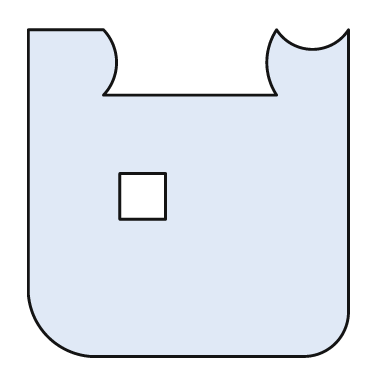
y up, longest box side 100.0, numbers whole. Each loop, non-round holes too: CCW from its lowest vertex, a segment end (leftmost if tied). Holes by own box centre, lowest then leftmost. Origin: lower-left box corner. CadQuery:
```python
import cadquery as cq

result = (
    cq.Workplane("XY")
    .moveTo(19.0, 0.0)
    .lineTo(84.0, 0.0)
    .threePointArc((94.0, 4.0), (98.0, 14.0))
    .lineTo(98.0, 100.0)
    .threePointArc((87.0, 94.0), (76.0, 100.0))
    .threePointArc((73.0, 90.0), (76.0, 80.0))
    .lineTo(23.0, 80.0)
    .threePointArc((27.0, 90.0), (23.0, 100.0))
    .lineTo(0.0, 100.0)
    .lineTo(0.0, 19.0)
    .threePointArc((6.0, 6.0), (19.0, 0.0))
    .close()
    .moveTo(28.0, 42.0)
    .lineTo(42.0, 42.0)
    .lineTo(42.0, 56.0)
    .lineTo(28.0, 56.0)
    .close()
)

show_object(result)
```